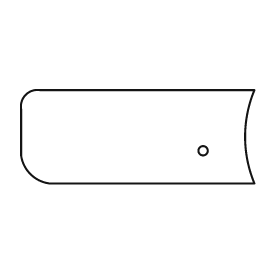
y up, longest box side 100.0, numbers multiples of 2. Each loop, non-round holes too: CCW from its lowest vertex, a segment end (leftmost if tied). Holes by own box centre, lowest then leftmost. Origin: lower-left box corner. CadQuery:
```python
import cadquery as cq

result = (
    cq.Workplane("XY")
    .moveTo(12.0, 0.0)
    .lineTo(100.0, 0.0)
    .threePointArc((96.0, 20.0), (100.0, 40.0))
    .lineTo(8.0, 40.0)
    .threePointArc((2.0, 38.0), (0.0, 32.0))
    .lineTo(0.0, 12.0)
    .threePointArc((4.0, 4.0), (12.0, 0.0))
    .close()
    .moveTo(78.0, 14.0)
    .circle(2.0)
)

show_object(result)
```